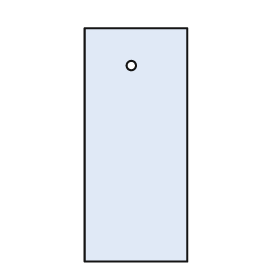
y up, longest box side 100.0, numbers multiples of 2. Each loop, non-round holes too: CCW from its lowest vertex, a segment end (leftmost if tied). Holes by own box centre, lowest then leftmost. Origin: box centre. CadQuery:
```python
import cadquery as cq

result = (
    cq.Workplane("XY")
    .moveTo(-22.0, -50.0)
    .lineTo(22.0, -50.0)
    .lineTo(22.0, 50.0)
    .lineTo(-22.0, 50.0)
    .close()
    .moveTo(-2.0, 34.0)
    .circle(2.0)
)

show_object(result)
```